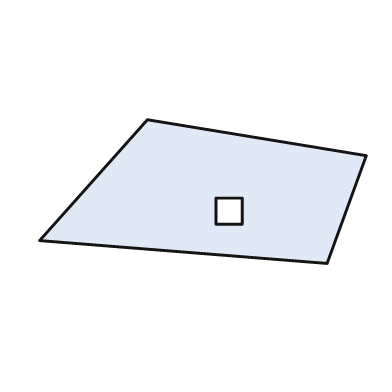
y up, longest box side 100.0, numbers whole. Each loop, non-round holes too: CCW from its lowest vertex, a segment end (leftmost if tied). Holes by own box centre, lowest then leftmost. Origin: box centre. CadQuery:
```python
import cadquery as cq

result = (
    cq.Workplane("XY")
    .moveTo(38.0, -22.0)
    .lineTo(50.0, 11.0)
    .lineTo(-17.0, 22.0)
    .lineTo(-50.0, -15.0)
    .close()
    .moveTo(4.0, -10.0)
    .lineTo(12.0, -10.0)
    .lineTo(12.0, -2.0)
    .lineTo(4.0, -2.0)
    .close()
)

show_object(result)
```